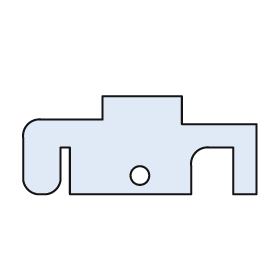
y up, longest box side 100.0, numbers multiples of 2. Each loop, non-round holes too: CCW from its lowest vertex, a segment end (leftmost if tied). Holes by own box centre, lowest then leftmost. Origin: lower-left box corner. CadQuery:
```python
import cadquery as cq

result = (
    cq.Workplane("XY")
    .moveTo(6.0, 0.0)
    .lineTo(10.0, 0.0)
    .threePointArc((14.0, 2.0), (16.0, 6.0))
    .lineTo(16.0, 20.0)
    .lineTo(20.0, 20.0)
    .lineTo(20.0, 0.0)
    .lineTo(72.0, 0.0)
    .lineTo(72.0, 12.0)
    .threePointArc((74.0, 18.0), (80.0, 20.0))
    .lineTo(90.0, 20.0)
    .lineTo(90.0, 0.0)
    .lineTo(100.0, 0.0)
    .lineTo(100.0, 30.0)
    .lineTo(68.0, 30.0)
    .lineTo(68.0, 42.0)
    .lineTo(34.0, 42.0)
    .lineTo(34.0, 32.0)
    .lineTo(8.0, 32.0)
    .threePointArc((2.0, 30.0), (0.0, 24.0))
    .lineTo(0.0, 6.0)
    .threePointArc((2.0, 2.0), (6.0, 0.0))
    .close()
    .moveTo(50.0, 8.0)
    .circle(4.0)
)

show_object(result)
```